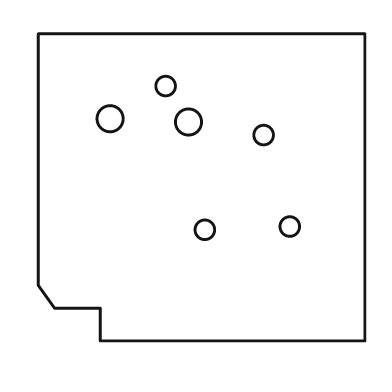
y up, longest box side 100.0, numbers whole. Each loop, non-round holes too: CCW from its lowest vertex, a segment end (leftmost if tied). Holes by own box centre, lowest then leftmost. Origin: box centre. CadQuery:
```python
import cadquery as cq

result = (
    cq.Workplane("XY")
    .moveTo(-31.0, -47.0)
    .lineTo(50.0, -47.0)
    .lineTo(50.0, 47.0)
    .lineTo(-50.0, 47.0)
    .lineTo(-50.0, -30.0)
    .lineTo(-45.0, -37.0)
    .lineTo(-31.0, -37.0)
    .close()
    .moveTo(1.0, -13.0)
    .circle(3.0)
    .moveTo(27.0, -12.0)
    .circle(3.0)
    .moveTo(19.0, 16.0)
    .circle(3.0)
    .moveTo(-4.0, 20.0)
    .circle(4.0)
    .moveTo(-28.0, 21.0)
    .circle(4.0)
    .moveTo(-11.0, 31.0)
    .circle(3.0)
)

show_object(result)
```